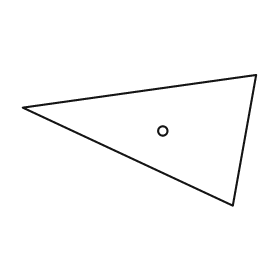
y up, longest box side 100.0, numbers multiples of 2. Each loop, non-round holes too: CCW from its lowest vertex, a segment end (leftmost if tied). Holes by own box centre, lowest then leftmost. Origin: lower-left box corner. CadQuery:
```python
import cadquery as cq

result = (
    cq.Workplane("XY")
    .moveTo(90.0, 0.0)
    .lineTo(100.0, 56.0)
    .lineTo(0.0, 42.0)
    .close()
    .moveTo(60.0, 32.0)
    .circle(2.0)
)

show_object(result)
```